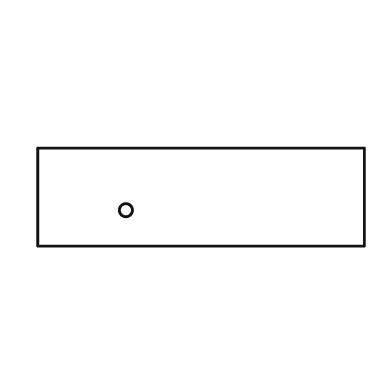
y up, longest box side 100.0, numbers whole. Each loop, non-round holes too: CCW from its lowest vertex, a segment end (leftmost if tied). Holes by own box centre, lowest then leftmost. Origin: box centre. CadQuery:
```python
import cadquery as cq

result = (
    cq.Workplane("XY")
    .moveTo(-50.0, -15.0)
    .lineTo(50.0, -15.0)
    .lineTo(50.0, 15.0)
    .lineTo(-50.0, 15.0)
    .close()
    .moveTo(-23.0, -4.0)
    .circle(2.0)
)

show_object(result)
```